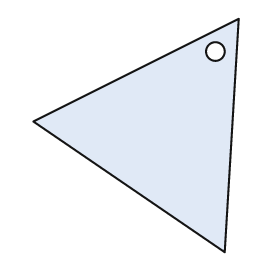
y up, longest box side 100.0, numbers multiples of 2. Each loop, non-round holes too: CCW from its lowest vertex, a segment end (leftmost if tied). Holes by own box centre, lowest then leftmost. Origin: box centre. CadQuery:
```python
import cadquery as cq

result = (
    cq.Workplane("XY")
    .moveTo(38.0, -50.0)
    .lineTo(44.0, 50.0)
    .lineTo(-44.0, 6.0)
    .close()
    .moveTo(34.0, 36.0)
    .circle(4.0)
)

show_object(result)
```